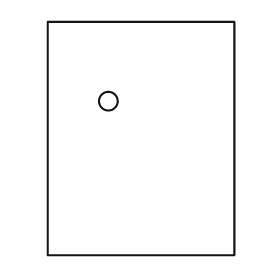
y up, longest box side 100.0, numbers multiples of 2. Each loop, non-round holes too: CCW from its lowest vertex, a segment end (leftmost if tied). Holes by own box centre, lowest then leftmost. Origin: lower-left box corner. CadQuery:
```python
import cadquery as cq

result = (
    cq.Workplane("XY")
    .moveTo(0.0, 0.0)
    .lineTo(80.0, 0.0)
    .lineTo(80.0, 100.0)
    .lineTo(0.0, 100.0)
    .close()
    .moveTo(26.0, 66.0)
    .circle(4.0)
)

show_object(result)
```